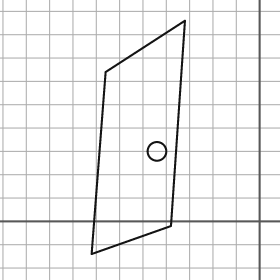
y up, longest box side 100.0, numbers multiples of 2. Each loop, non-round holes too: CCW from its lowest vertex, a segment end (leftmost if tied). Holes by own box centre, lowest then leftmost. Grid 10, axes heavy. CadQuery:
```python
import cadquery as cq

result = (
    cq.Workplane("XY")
    .moveTo(-72.0, -14.0)
    .lineTo(-38.0, -2.0)
    .lineTo(-32.0, 86.0)
    .lineTo(-66.0, 64.0)
    .close()
    .moveTo(-44.0, 30.0)
    .circle(4.0)
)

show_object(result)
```